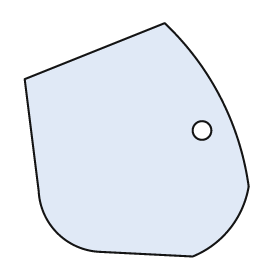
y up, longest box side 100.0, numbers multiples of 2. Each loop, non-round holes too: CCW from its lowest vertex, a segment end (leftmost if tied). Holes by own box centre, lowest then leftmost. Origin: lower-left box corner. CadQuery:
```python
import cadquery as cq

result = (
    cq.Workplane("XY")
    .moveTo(72.0, 0.0)
    .threePointArc((88.0, 12.0), (96.0, 30.0))
    .threePointArc((84.0, 68.0), (60.0, 100.0))
    .lineTo(0.0, 76.0)
    .lineTo(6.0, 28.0)
    .threePointArc((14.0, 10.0), (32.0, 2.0))
    .close()
    .moveTo(76.0, 54.0)
    .circle(4.0)
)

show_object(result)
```